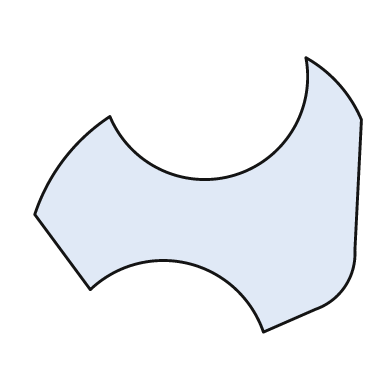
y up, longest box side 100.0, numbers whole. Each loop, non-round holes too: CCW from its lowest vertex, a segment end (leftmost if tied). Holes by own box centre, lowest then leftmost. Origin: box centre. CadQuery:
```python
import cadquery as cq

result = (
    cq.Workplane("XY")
    .moveTo(20.0, -42.0)
    .lineTo(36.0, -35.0)
    .threePointArc((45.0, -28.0), (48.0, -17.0))
    .lineTo(50.0, 23.0)
    .threePointArc((43.0, 34.0), (33.0, 42.0))
    .threePointArc((11.0, 6.0), (-27.0, 24.0))
    .threePointArc((-41.0, 11.0), (-50.0, -6.0))
    .lineTo(-33.0, -29.0)
    .threePointArc((-3.0, -21.0), (20.0, -42.0))
    .close()
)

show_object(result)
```